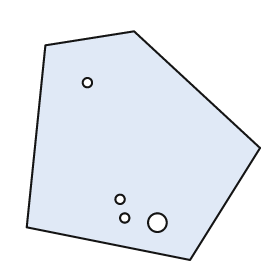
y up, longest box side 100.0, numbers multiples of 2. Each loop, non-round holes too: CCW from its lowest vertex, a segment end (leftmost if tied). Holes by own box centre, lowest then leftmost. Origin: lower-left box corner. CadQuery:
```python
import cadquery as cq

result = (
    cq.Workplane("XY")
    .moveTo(70.0, 0.0)
    .lineTo(100.0, 48.0)
    .lineTo(46.0, 98.0)
    .lineTo(8.0, 92.0)
    .lineTo(0.0, 14.0)
    .close()
    .moveTo(56.0, 16.0)
    .circle(4.0)
    .moveTo(42.0, 18.0)
    .circle(2.0)
    .moveTo(40.0, 26.0)
    .circle(2.0)
    .moveTo(26.0, 76.0)
    .circle(2.0)
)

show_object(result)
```